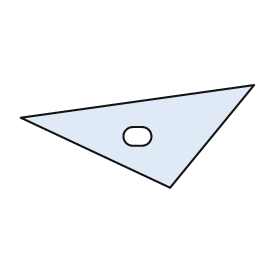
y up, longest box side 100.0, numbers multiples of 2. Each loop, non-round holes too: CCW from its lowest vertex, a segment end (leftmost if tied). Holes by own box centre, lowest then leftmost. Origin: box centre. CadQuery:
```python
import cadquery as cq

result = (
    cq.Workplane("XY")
    .moveTo(14.0, -22.0)
    .lineTo(50.0, 22.0)
    .lineTo(-50.0, 8.0)
    .close()
    .moveTo(-2.0, -4.0)
    .lineTo(2.0, -4.0)
    .threePointArc((6.0, 0.0), (2.0, 4.0))
    .lineTo(-2.0, 4.0)
    .threePointArc((-6.0, 0.0), (-2.0, -4.0))
    .close()
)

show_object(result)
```